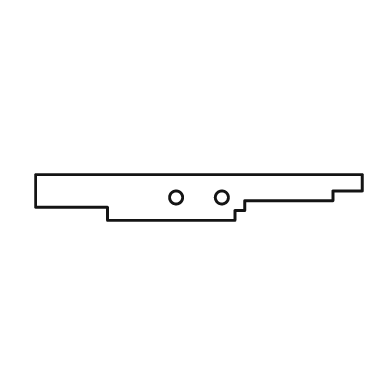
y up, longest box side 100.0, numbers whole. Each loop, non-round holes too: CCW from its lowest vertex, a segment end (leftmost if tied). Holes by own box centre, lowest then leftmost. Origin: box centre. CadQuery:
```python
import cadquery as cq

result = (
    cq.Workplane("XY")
    .moveTo(-28.0, -7.0)
    .lineTo(11.0, -7.0)
    .lineTo(11.0, -4.0)
    .lineTo(14.0, -4.0)
    .lineTo(14.0, -1.0)
    .lineTo(41.0, -1.0)
    .lineTo(41.0, 2.0)
    .lineTo(50.0, 2.0)
    .lineTo(50.0, 7.0)
    .lineTo(-50.0, 7.0)
    .lineTo(-50.0, -3.0)
    .lineTo(-28.0, -3.0)
    .close()
    .moveTo(-7.0, 0.0)
    .circle(2.0)
    .moveTo(7.0, 0.0)
    .circle(2.0)
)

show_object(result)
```